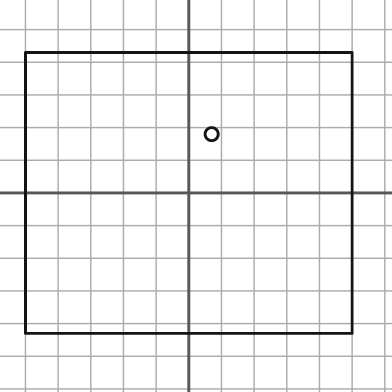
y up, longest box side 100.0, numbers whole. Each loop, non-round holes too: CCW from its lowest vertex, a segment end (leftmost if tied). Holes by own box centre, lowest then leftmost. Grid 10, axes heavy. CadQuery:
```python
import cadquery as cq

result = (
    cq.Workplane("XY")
    .moveTo(-50.0, -43.0)
    .lineTo(50.0, -43.0)
    .lineTo(50.0, 43.0)
    .lineTo(-50.0, 43.0)
    .close()
    .moveTo(7.0, 18.0)
    .circle(2.0)
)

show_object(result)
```